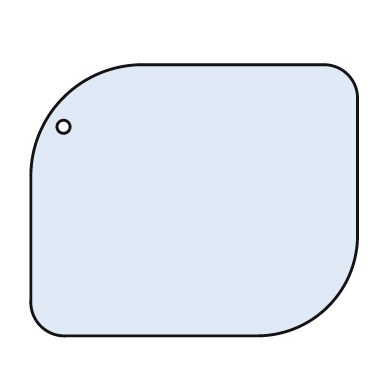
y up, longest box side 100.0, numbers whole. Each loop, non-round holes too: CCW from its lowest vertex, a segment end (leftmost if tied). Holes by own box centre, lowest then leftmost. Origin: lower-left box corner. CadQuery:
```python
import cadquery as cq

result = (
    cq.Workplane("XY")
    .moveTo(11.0, 0.0)
    .lineTo(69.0, 0.0)
    .threePointArc((91.0, 9.0), (100.0, 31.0))
    .lineTo(100.0, 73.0)
    .threePointArc((97.0, 80.0), (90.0, 83.0))
    .lineTo(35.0, 83.0)
    .threePointArc((10.0, 73.0), (0.0, 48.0))
    .lineTo(0.0, 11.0)
    .threePointArc((3.0, 3.0), (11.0, 0.0))
    .close()
    .moveTo(10.0, 64.0)
    .circle(2.0)
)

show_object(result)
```